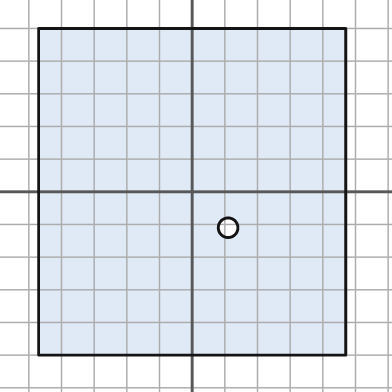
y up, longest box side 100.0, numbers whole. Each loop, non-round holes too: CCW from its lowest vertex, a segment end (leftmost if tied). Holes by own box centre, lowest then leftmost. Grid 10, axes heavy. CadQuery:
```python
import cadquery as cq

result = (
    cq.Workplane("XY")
    .moveTo(-47.0, -50.0)
    .lineTo(47.0, -50.0)
    .lineTo(47.0, 50.0)
    .lineTo(-47.0, 50.0)
    .close()
    .moveTo(11.0, -11.0)
    .circle(3.0)
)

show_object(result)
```